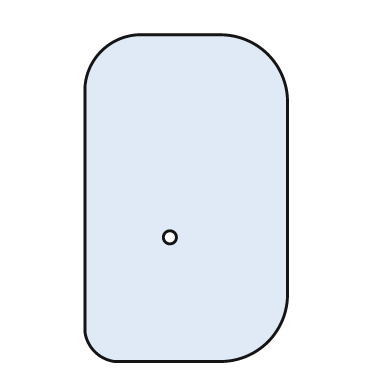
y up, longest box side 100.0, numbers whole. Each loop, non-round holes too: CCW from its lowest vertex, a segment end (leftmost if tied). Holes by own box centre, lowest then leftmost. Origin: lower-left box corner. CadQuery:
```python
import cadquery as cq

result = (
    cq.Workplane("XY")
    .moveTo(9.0, 0.0)
    .lineTo(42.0, 0.0)
    .threePointArc((56.0, 6.0), (62.0, 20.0))
    .lineTo(62.0, 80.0)
    .threePointArc((56.0, 94.0), (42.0, 100.0))
    .lineTo(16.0, 100.0)
    .threePointArc((5.0, 95.0), (0.0, 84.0))
    .lineTo(0.0, 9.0)
    .threePointArc((3.0, 3.0), (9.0, 0.0))
    .close()
    .moveTo(26.0, 38.0)
    .circle(2.0)
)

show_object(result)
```